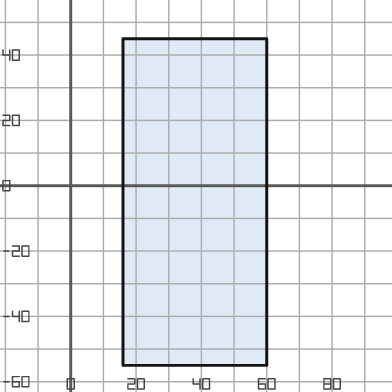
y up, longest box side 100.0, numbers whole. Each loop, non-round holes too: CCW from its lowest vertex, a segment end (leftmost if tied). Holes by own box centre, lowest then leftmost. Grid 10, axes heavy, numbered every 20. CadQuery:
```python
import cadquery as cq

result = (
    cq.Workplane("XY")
    .moveTo(16.0, -55.0)
    .lineTo(60.0, -55.0)
    .lineTo(60.0, 45.0)
    .lineTo(16.0, 45.0)
    .close()
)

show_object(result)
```